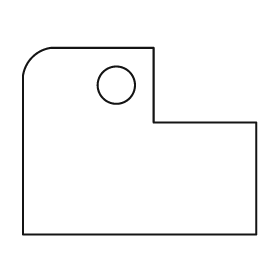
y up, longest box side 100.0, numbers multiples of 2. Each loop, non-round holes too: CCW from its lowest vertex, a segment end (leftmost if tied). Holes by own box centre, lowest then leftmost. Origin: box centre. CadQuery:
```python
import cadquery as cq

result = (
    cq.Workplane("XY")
    .moveTo(-50.0, -40.0)
    .lineTo(50.0, -40.0)
    .lineTo(50.0, 8.0)
    .lineTo(6.0, 8.0)
    .lineTo(6.0, 40.0)
    .lineTo(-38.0, 40.0)
    .threePointArc((-46.0, 36.0), (-50.0, 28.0))
    .close()
    .moveTo(-10.0, 24.0)
    .circle(8.0)
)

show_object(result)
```